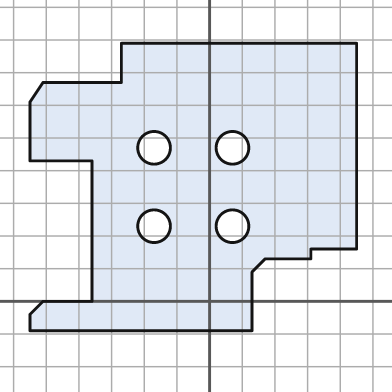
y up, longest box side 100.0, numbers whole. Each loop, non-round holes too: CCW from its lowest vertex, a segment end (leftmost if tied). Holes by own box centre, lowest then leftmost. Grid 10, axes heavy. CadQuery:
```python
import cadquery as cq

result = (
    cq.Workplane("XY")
    .moveTo(-55.0, -9.0)
    .lineTo(13.0, -9.0)
    .lineTo(13.0, 9.0)
    .lineTo(17.0, 13.0)
    .lineTo(31.0, 13.0)
    .lineTo(31.0, 16.0)
    .lineTo(45.0, 16.0)
    .lineTo(45.0, 79.0)
    .lineTo(-27.0, 79.0)
    .lineTo(-27.0, 67.0)
    .lineTo(-51.0, 67.0)
    .lineTo(-55.0, 61.0)
    .lineTo(-55.0, 43.0)
    .lineTo(-36.0, 43.0)
    .lineTo(-36.0, 0.0)
    .lineTo(-51.0, 0.0)
    .lineTo(-55.0, -4.0)
    .close()
    .moveTo(-17.0, 23.0)
    .circle(5.0)
    .moveTo(7.0, 23.0)
    .circle(5.0)
    .moveTo(-17.0, 47.0)
    .circle(5.0)
    .moveTo(7.0, 47.0)
    .circle(5.0)
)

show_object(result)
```